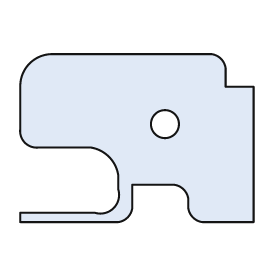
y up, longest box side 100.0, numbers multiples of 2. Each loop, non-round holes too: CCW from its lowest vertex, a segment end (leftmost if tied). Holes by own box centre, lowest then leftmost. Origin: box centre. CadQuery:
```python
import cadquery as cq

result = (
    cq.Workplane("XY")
    .moveTo(-50.0, -36.0)
    .lineTo(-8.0, -36.0)
    .threePointArc((-4.0, -34.0), (-2.0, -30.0))
    .lineTo(-2.0, -20.0)
    .lineTo(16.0, -20.0)
    .threePointArc((20.0, -22.0), (22.0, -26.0))
    .lineTo(22.0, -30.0)
    .threePointArc((24.0, -34.0), (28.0, -36.0))
    .lineTo(50.0, -36.0)
    .lineTo(50.0, 22.0)
    .lineTo(38.0, 22.0)
    .lineTo(38.0, 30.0)
    .threePointArc((36.0, 34.0), (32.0, 36.0))
    .lineTo(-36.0, 36.0)
    .threePointArc((-46.0, 32.0), (-50.0, 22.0))
    .lineTo(-50.0, 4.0)
    .threePointArc((-48.0, -2.0), (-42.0, -4.0))
    .lineTo(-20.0, -4.0)
    .threePointArc((-12.0, -8.0), (-8.0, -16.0))
    .lineTo(-8.0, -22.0)
    .threePointArc((-10.0, -30.0), (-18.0, -32.0))
    .lineTo(-50.0, -32.0)
    .close()
    .moveTo(12.0, 6.0)
    .circle(6.0)
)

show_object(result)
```